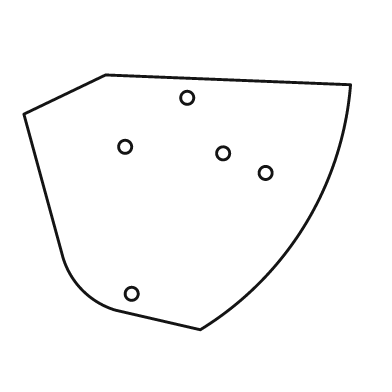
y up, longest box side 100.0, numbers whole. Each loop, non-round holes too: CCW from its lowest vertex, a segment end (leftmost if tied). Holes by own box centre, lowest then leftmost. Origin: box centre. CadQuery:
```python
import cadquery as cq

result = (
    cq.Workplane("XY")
    .moveTo(4.0, -39.0)
    .threePointArc((36.0, -7.0), (50.0, 36.0))
    .lineTo(-25.0, 39.0)
    .lineTo(-50.0, 27.0)
    .lineTo(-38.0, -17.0)
    .threePointArc((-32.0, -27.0), (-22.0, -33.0))
    .close()
    .moveTo(-17.0, -28.0)
    .circle(2.0)
    .moveTo(24.0, 9.0)
    .circle(2.0)
    .moveTo(11.0, 15.0)
    .circle(2.0)
    .moveTo(-19.0, 17.0)
    .circle(2.0)
    .moveTo(0.0, 32.0)
    .circle(2.0)
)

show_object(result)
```